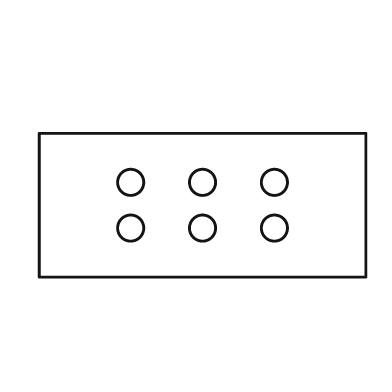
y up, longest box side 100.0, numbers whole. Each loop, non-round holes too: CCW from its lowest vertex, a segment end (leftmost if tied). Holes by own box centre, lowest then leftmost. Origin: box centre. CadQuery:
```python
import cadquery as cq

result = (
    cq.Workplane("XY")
    .moveTo(-50.0, -22.0)
    .lineTo(50.0, -22.0)
    .lineTo(50.0, 22.0)
    .lineTo(-50.0, 22.0)
    .close()
    .moveTo(-22.0, -7.0)
    .circle(4.0)
    .moveTo(0.0, -7.0)
    .circle(4.0)
    .moveTo(22.0, -7.0)
    .circle(4.0)
    .moveTo(-22.0, 7.0)
    .circle(4.0)
    .moveTo(0.0, 7.0)
    .circle(4.0)
    .moveTo(22.0, 7.0)
    .circle(4.0)
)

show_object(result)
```